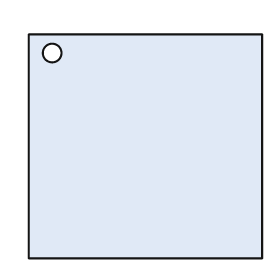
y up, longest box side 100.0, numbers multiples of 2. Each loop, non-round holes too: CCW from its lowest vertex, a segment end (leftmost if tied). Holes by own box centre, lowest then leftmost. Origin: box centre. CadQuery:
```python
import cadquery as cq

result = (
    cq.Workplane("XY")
    .moveTo(-50.0, -48.0)
    .lineTo(50.0, -48.0)
    .lineTo(50.0, 48.0)
    .lineTo(-50.0, 48.0)
    .close()
    .moveTo(-40.0, 40.0)
    .circle(4.0)
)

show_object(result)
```